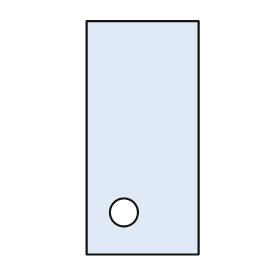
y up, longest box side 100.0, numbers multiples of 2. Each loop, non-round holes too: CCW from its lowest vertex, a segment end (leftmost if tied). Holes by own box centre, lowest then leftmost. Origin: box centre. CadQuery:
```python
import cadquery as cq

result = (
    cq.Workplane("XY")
    .moveTo(-24.0, -50.0)
    .lineTo(24.0, -50.0)
    .lineTo(24.0, 50.0)
    .lineTo(-24.0, 50.0)
    .close()
    .moveTo(-8.0, -32.0)
    .circle(6.0)
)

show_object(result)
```